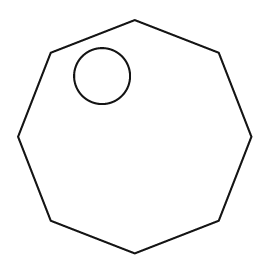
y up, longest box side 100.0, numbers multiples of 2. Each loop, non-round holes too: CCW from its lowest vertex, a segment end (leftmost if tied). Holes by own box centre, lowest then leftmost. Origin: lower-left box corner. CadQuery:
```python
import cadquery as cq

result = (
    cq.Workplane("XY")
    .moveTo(50.0, 0.0)
    .lineTo(86.0, 14.0)
    .lineTo(100.0, 50.0)
    .lineTo(86.0, 86.0)
    .lineTo(50.0, 100.0)
    .lineTo(14.0, 86.0)
    .lineTo(0.0, 50.0)
    .lineTo(14.0, 14.0)
    .close()
    .moveTo(36.0, 76.0)
    .circle(12.0)
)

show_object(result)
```